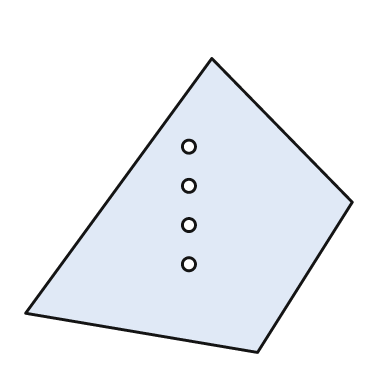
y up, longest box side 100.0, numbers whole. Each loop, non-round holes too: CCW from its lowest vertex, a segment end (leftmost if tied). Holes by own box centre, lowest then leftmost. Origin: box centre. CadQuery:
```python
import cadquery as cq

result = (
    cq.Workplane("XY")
    .moveTo(21.0, -45.0)
    .lineTo(50.0, 1.0)
    .lineTo(7.0, 45.0)
    .lineTo(-50.0, -33.0)
    .close()
    .moveTo(0.0, -18.0)
    .circle(2.0)
    .moveTo(0.0, -6.0)
    .circle(2.0)
    .moveTo(0.0, 6.0)
    .circle(2.0)
    .moveTo(0.0, 18.0)
    .circle(2.0)
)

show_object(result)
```